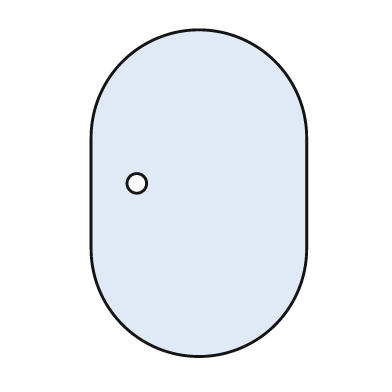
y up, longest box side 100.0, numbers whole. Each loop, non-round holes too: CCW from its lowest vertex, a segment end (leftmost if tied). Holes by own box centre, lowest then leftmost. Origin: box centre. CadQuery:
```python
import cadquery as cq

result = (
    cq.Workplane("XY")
    .moveTo(-33.0, -17.0)
    .threePointArc((0.0, -50.0), (33.0, -17.0))
    .lineTo(33.0, 17.0)
    .threePointArc((0.0, 50.0), (-33.0, 17.0))
    .close()
    .moveTo(-19.0, 3.0)
    .circle(3.0)
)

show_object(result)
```